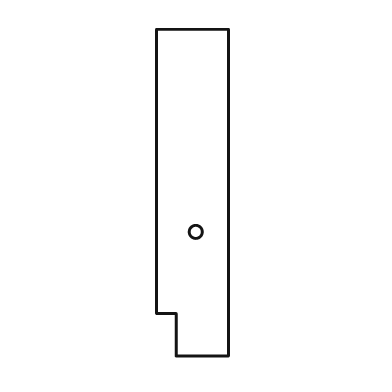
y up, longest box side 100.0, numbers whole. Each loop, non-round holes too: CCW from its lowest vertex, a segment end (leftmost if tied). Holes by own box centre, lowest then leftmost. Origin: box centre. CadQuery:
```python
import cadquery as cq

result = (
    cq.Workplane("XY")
    .moveTo(-5.0, -50.0)
    .lineTo(11.0, -50.0)
    .lineTo(11.0, 50.0)
    .lineTo(-11.0, 50.0)
    .lineTo(-11.0, -37.0)
    .lineTo(-5.0, -37.0)
    .close()
    .moveTo(1.0, -12.0)
    .circle(2.0)
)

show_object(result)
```